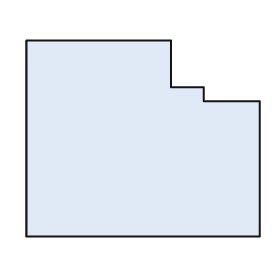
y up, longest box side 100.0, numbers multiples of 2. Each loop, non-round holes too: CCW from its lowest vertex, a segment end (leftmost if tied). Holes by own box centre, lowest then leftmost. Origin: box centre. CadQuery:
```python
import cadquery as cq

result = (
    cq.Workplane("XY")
    .moveTo(-50.0, -42.0)
    .lineTo(50.0, -42.0)
    .lineTo(50.0, 16.0)
    .lineTo(26.0, 16.0)
    .lineTo(26.0, 22.0)
    .lineTo(12.0, 22.0)
    .lineTo(12.0, 42.0)
    .lineTo(-50.0, 42.0)
    .close()
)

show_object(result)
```